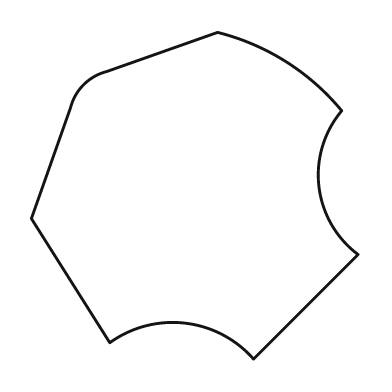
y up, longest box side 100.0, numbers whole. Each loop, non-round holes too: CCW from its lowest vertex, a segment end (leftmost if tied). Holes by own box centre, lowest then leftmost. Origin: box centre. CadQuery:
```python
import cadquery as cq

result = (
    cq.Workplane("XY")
    .moveTo(18.0, -50.0)
    .lineTo(50.0, -18.0)
    .threePointArc((38.0, 3.0), (45.0, 26.0))
    .threePointArc((28.0, 41.0), (7.0, 50.0))
    .lineTo(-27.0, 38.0)
    .threePointArc((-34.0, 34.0), (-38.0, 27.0))
    .lineTo(-50.0, -7.0)
    .lineTo(-26.0, -45.0)
    .threePointArc((-3.0, -39.0), (18.0, -50.0))
    .close()
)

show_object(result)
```